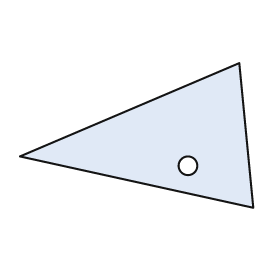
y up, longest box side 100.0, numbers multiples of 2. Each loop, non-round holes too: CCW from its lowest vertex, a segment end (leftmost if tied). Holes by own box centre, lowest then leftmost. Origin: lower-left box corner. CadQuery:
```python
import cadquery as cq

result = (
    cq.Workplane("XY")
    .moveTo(100.0, 0.0)
    .lineTo(94.0, 62.0)
    .lineTo(0.0, 22.0)
    .close()
    .moveTo(72.0, 18.0)
    .circle(4.0)
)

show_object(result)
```